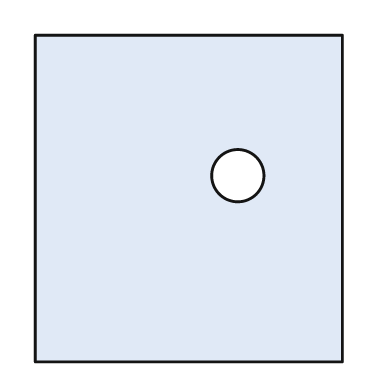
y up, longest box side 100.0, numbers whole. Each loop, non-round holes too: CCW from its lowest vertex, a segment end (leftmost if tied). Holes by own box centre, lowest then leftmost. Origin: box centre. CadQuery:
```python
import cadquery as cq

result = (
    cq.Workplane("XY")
    .moveTo(-47.0, -50.0)
    .lineTo(47.0, -50.0)
    .lineTo(47.0, 50.0)
    .lineTo(-47.0, 50.0)
    .close()
    .moveTo(15.0, 7.0)
    .circle(8.0)
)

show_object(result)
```